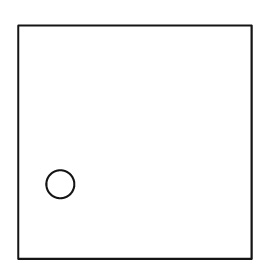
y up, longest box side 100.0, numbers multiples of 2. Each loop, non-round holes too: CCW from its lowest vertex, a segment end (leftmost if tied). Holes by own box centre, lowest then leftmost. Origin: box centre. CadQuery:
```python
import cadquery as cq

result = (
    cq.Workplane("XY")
    .moveTo(-50.0, -50.0)
    .lineTo(50.0, -50.0)
    .lineTo(50.0, 50.0)
    .lineTo(-50.0, 50.0)
    .close()
    .moveTo(-32.0, -18.0)
    .circle(6.0)
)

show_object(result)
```